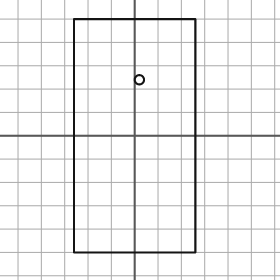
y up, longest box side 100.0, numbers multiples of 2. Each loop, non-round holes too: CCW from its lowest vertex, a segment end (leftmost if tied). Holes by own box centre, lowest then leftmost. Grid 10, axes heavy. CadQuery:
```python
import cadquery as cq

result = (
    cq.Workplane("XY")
    .moveTo(-26.0, -50.0)
    .lineTo(26.0, -50.0)
    .lineTo(26.0, 50.0)
    .lineTo(-26.0, 50.0)
    .close()
    .moveTo(2.0, 24.0)
    .circle(2.0)
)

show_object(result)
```